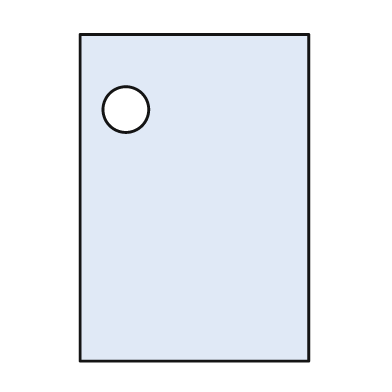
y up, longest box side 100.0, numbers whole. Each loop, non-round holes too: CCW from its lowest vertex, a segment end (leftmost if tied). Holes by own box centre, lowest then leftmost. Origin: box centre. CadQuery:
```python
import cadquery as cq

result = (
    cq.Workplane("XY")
    .moveTo(-35.0, -50.0)
    .lineTo(35.0, -50.0)
    .lineTo(35.0, 50.0)
    .lineTo(-35.0, 50.0)
    .close()
    .moveTo(-21.0, 27.0)
    .circle(7.0)
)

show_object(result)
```